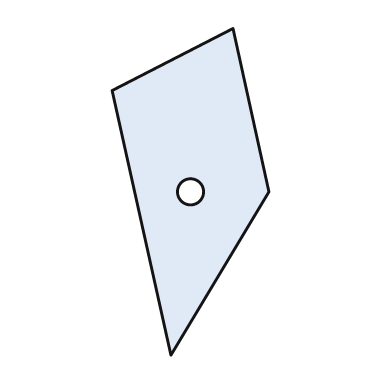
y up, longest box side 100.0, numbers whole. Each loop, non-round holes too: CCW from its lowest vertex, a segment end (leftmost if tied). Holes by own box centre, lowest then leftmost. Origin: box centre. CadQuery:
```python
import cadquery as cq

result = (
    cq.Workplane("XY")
    .moveTo(-6.0, -50.0)
    .lineTo(24.0, 0.0)
    .lineTo(13.0, 50.0)
    .lineTo(-24.0, 31.0)
    .close()
    .moveTo(0.0, 0.0)
    .circle(4.0)
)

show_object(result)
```